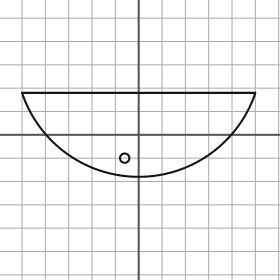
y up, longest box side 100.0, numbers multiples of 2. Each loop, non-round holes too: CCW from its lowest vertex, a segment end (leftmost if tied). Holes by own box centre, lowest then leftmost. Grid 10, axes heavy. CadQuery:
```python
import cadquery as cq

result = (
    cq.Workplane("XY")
    .moveTo(-50.0, 18.0)
    .threePointArc((0.0, -18.0), (50.0, 18.0))
    .close()
    .moveTo(-6.0, -10.0)
    .circle(2.0)
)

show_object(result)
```